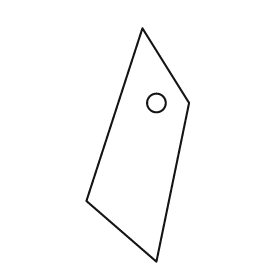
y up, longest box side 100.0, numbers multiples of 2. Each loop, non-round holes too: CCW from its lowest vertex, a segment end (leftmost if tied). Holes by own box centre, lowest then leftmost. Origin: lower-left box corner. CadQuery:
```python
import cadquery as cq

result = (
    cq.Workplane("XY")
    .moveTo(30.0, 0.0)
    .lineTo(44.0, 68.0)
    .lineTo(24.0, 100.0)
    .lineTo(0.0, 26.0)
    .close()
    .moveTo(30.0, 68.0)
    .circle(4.0)
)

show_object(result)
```